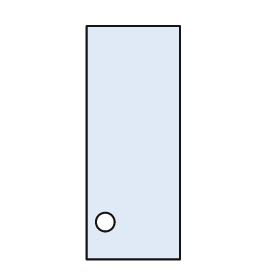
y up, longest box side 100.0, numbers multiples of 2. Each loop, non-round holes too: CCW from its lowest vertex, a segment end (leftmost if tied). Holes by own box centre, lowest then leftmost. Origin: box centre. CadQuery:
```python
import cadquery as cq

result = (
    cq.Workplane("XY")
    .moveTo(-20.0, -50.0)
    .lineTo(20.0, -50.0)
    .lineTo(20.0, 50.0)
    .lineTo(-20.0, 50.0)
    .close()
    .moveTo(-12.0, -34.0)
    .circle(4.0)
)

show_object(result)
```